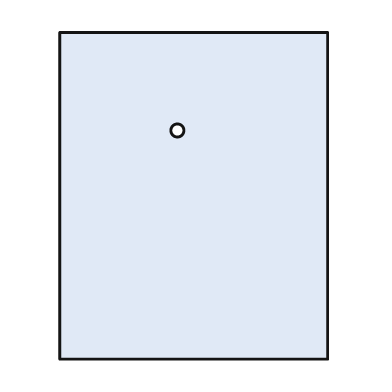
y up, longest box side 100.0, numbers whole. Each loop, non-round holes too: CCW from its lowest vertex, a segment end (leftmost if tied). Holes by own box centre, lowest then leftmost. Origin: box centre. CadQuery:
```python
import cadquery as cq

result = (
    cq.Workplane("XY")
    .moveTo(-41.0, -50.0)
    .lineTo(41.0, -50.0)
    .lineTo(41.0, 50.0)
    .lineTo(-41.0, 50.0)
    .close()
    .moveTo(-5.0, 20.0)
    .circle(2.0)
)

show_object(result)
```